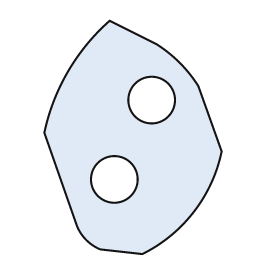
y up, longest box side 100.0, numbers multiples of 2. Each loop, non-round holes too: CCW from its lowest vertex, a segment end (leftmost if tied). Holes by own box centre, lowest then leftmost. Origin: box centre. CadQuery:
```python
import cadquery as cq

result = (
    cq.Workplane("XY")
    .moveTo(4.0, -50.0)
    .threePointArc((26.0, -32.0), (38.0, -6.0))
    .lineTo(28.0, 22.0)
    .threePointArc((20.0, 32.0), (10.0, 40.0))
    .lineTo(-10.0, 50.0)
    .threePointArc((-28.0, 28.0), (-38.0, 2.0))
    .lineTo(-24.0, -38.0)
    .threePointArc((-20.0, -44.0), (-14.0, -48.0))
    .close()
    .moveTo(-8.0, -18.0)
    .circle(10.0)
    .moveTo(8.0, 16.0)
    .circle(10.0)
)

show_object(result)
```